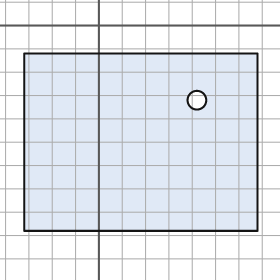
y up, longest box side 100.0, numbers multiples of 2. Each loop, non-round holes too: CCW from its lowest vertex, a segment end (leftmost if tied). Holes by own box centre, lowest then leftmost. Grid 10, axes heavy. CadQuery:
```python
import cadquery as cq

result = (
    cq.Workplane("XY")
    .moveTo(-32.0, -88.0)
    .lineTo(68.0, -88.0)
    .lineTo(68.0, -12.0)
    .lineTo(-32.0, -12.0)
    .close()
    .moveTo(42.0, -32.0)
    .circle(4.0)
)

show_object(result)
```